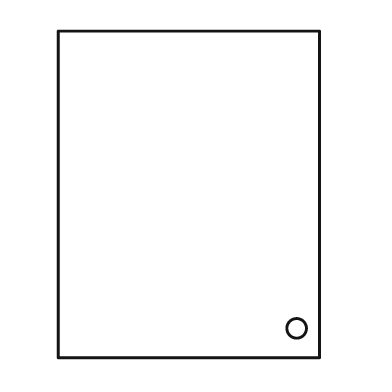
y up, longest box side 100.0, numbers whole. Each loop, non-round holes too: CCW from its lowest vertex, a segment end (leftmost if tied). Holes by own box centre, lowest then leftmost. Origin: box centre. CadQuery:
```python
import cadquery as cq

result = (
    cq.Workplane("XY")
    .moveTo(-40.0, -50.0)
    .lineTo(40.0, -50.0)
    .lineTo(40.0, 50.0)
    .lineTo(-40.0, 50.0)
    .close()
    .moveTo(33.0, -41.0)
    .circle(3.0)
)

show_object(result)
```